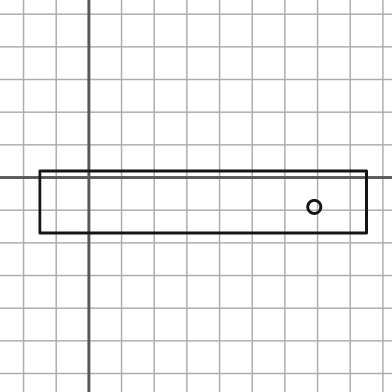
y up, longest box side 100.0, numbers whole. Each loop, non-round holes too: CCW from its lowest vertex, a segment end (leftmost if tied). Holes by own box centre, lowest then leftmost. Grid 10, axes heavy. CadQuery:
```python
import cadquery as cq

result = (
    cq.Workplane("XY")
    .moveTo(-15.0, -17.0)
    .lineTo(85.0, -17.0)
    .lineTo(85.0, 2.0)
    .lineTo(-15.0, 2.0)
    .close()
    .moveTo(69.0, -9.0)
    .circle(2.0)
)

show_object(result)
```